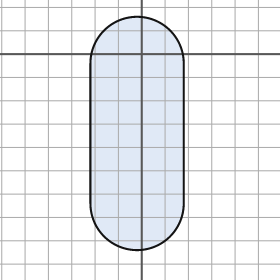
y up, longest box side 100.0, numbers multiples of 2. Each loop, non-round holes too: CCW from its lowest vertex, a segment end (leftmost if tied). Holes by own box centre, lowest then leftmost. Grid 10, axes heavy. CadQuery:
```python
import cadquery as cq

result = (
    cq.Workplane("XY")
    .moveTo(-22.0, -64.0)
    .threePointArc((-2.0, -84.0), (18.0, -64.0))
    .lineTo(18.0, -4.0)
    .threePointArc((-2.0, 16.0), (-22.0, -4.0))
    .close()
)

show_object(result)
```